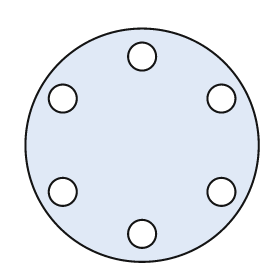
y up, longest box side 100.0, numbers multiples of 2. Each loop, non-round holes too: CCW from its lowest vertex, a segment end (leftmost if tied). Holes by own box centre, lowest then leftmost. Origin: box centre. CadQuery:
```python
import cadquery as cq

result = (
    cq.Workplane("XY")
    .moveTo(0.0, 0.0)
    .circle(50.0)
    .moveTo(0.0, -38.0)
    .circle(6.0)
    .moveTo(-34.0, -20.0)
    .circle(6.0)
    .moveTo(34.0, -20.0)
    .circle(6.0)
    .moveTo(-34.0, 20.0)
    .circle(6.0)
    .moveTo(34.0, 20.0)
    .circle(6.0)
    .moveTo(0.0, 38.0)
    .circle(6.0)
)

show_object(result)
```